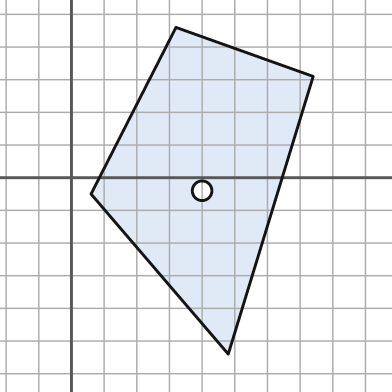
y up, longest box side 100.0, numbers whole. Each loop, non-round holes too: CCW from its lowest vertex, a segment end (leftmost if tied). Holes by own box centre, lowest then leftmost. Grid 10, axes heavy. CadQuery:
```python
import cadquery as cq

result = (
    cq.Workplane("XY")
    .moveTo(48.0, -54.0)
    .lineTo(74.0, 31.0)
    .lineTo(32.0, 46.0)
    .lineTo(6.0, -5.0)
    .close()
    .moveTo(40.0, -4.0)
    .circle(3.0)
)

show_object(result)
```